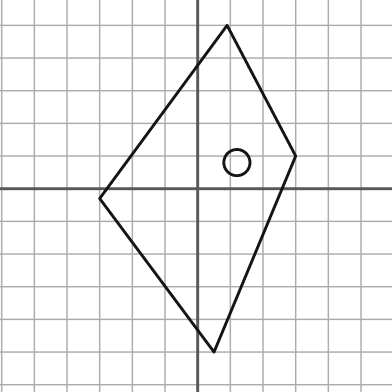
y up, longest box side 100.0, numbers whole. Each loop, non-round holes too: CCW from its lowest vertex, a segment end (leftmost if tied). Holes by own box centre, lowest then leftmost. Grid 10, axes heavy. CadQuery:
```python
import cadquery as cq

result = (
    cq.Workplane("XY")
    .moveTo(5.0, -50.0)
    .lineTo(30.0, 10.0)
    .lineTo(9.0, 50.0)
    .lineTo(-30.0, -3.0)
    .close()
    .moveTo(12.0, 8.0)
    .circle(4.0)
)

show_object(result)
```